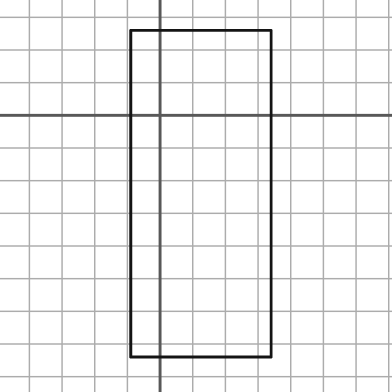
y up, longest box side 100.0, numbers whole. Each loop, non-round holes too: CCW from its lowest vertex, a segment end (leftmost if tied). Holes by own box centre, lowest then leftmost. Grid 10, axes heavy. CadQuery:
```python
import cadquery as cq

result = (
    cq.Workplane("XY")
    .moveTo(-9.0, -74.0)
    .lineTo(34.0, -74.0)
    .lineTo(34.0, 26.0)
    .lineTo(-9.0, 26.0)
    .close()
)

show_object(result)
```